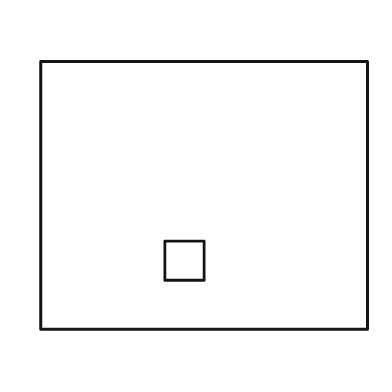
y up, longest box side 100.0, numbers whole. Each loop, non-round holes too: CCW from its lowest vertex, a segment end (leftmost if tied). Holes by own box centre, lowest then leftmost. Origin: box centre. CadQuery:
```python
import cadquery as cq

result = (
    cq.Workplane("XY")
    .moveTo(-50.0, -41.0)
    .lineTo(50.0, -41.0)
    .lineTo(50.0, 41.0)
    .lineTo(-50.0, 41.0)
    .close()
    .moveTo(-12.0, -26.0)
    .lineTo(0.0, -26.0)
    .lineTo(0.0, -14.0)
    .lineTo(-12.0, -14.0)
    .close()
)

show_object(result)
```